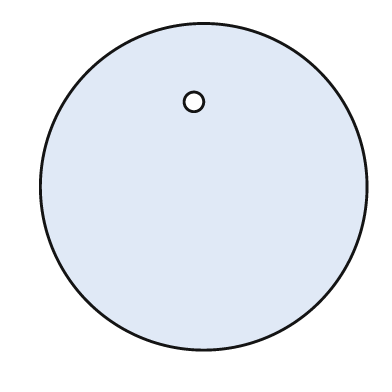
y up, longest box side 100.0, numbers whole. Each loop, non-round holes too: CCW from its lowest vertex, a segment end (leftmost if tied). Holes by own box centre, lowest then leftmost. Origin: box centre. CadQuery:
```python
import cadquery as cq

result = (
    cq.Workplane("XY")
    .moveTo(0.0, 0.0)
    .circle(50.0)
    .moveTo(-3.0, 26.0)
    .circle(3.0)
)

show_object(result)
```